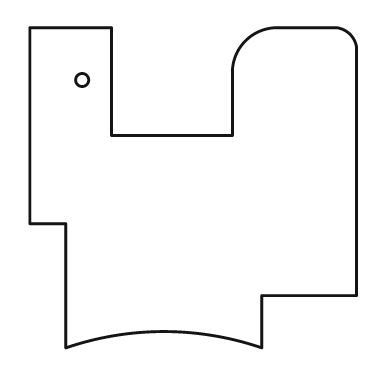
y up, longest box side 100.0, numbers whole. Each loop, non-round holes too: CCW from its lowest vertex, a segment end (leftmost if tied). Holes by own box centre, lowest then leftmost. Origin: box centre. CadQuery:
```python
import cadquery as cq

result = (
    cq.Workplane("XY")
    .moveTo(-39.0, -49.0)
    .threePointArc((-9.0, -44.0), (21.0, -49.0))
    .lineTo(21.0, -33.0)
    .lineTo(50.0, -33.0)
    .lineTo(50.0, 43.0)
    .threePointArc((48.0, 47.0), (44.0, 49.0))
    .lineTo(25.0, 49.0)
    .threePointArc((16.0, 45.0), (12.0, 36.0))
    .lineTo(12.0, 16.0)
    .lineTo(-25.0, 16.0)
    .lineTo(-25.0, 49.0)
    .lineTo(-50.0, 49.0)
    .lineTo(-50.0, -11.0)
    .lineTo(-39.0, -11.0)
    .close()
    .moveTo(-34.0, 33.0)
    .circle(2.0)
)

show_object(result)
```